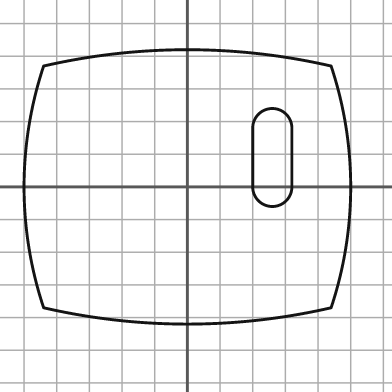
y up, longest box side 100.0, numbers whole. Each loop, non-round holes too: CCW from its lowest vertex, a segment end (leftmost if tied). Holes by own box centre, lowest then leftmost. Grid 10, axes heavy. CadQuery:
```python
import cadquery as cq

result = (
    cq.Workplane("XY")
    .moveTo(-44.0, -37.0)
    .threePointArc((0.0, -42.0), (44.0, -37.0))
    .threePointArc((50.0, 0.0), (44.0, 37.0))
    .threePointArc((0.0, 42.0), (-44.0, 37.0))
    .threePointArc((-50.0, 0.0), (-44.0, -37.0))
    .close()
    .moveTo(20.0, 0.0)
    .threePointArc((26.0, -6.0), (32.0, 0.0))
    .lineTo(32.0, 18.0)
    .threePointArc((26.0, 24.0), (20.0, 18.0))
    .close()
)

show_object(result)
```